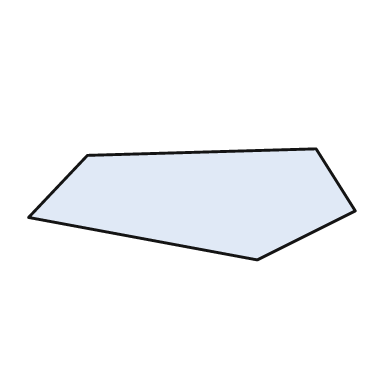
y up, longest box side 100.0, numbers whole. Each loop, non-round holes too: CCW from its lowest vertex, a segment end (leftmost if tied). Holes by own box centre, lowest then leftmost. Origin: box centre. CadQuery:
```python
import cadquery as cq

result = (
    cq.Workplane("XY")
    .moveTo(20.0, -17.0)
    .lineTo(50.0, -2.0)
    .lineTo(38.0, 17.0)
    .lineTo(-32.0, 15.0)
    .lineTo(-50.0, -4.0)
    .close()
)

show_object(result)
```